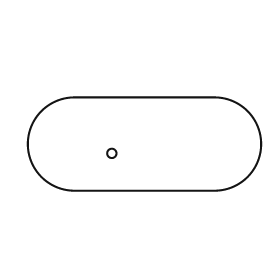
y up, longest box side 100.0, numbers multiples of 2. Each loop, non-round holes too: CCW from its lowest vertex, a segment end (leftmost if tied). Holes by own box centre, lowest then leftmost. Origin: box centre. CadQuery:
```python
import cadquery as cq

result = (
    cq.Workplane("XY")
    .moveTo(-30.0, -20.0)
    .lineTo(30.0, -20.0)
    .threePointArc((50.0, 0.0), (30.0, 20.0))
    .lineTo(-30.0, 20.0)
    .threePointArc((-50.0, 0.0), (-30.0, -20.0))
    .close()
    .moveTo(-14.0, -4.0)
    .circle(2.0)
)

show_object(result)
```